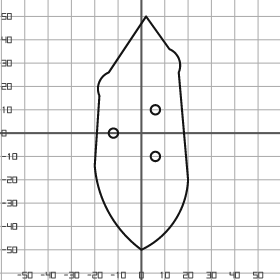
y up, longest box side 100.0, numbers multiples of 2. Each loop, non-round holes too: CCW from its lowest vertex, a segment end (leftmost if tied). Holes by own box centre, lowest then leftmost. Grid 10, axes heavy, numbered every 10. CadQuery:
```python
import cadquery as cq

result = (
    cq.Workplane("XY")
    .moveTo(0.0, -50.0)
    .threePointArc((14.0, -38.0), (20.0, -20.0))
    .lineTo(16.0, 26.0)
    .threePointArc((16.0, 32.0), (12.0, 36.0))
    .lineTo(2.0, 50.0)
    .lineTo(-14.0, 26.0)
    .threePointArc((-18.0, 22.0), (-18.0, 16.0))
    .lineTo(-20.0, -14.0)
    .threePointArc((-14.0, -34.0), (0.0, -50.0))
    .close()
    .moveTo(6.0, -10.0)
    .circle(2.0)
    .moveTo(-12.0, 0.0)
    .circle(2.0)
    .moveTo(6.0, 10.0)
    .circle(2.0)
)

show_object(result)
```